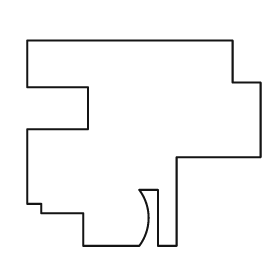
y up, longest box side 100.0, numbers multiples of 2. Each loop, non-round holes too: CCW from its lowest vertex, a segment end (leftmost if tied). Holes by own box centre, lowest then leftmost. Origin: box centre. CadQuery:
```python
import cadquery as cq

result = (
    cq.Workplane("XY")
    .moveTo(-26.0, -44.0)
    .lineTo(-2.0, -44.0)
    .threePointArc((2.0, -32.0), (-2.0, -20.0))
    .lineTo(6.0, -20.0)
    .lineTo(6.0, -44.0)
    .lineTo(14.0, -44.0)
    .lineTo(14.0, -6.0)
    .lineTo(50.0, -6.0)
    .lineTo(50.0, 26.0)
    .lineTo(38.0, 26.0)
    .lineTo(38.0, 44.0)
    .lineTo(-50.0, 44.0)
    .lineTo(-50.0, 24.0)
    .lineTo(-24.0, 24.0)
    .lineTo(-24.0, 6.0)
    .lineTo(-50.0, 6.0)
    .lineTo(-50.0, -26.0)
    .lineTo(-44.0, -26.0)
    .lineTo(-44.0, -30.0)
    .lineTo(-26.0, -30.0)
    .close()
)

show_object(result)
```